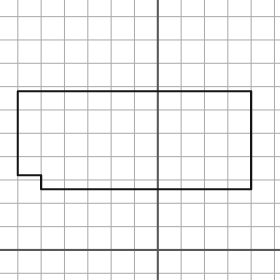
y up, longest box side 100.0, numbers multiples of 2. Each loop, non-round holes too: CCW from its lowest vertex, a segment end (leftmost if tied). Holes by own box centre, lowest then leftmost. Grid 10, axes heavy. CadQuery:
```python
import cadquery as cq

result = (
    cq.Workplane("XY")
    .moveTo(-50.0, 26.0)
    .lineTo(40.0, 26.0)
    .lineTo(40.0, 68.0)
    .lineTo(-60.0, 68.0)
    .lineTo(-60.0, 32.0)
    .lineTo(-50.0, 32.0)
    .close()
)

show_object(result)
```